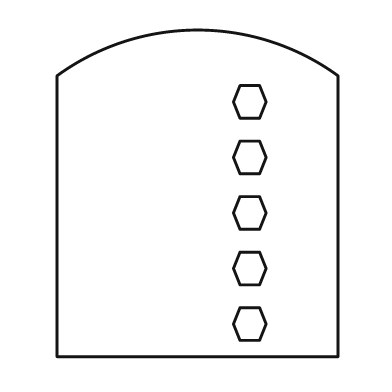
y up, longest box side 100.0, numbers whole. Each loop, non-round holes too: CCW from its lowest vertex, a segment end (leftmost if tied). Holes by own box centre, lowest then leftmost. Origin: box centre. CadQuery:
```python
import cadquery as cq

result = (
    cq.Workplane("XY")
    .moveTo(-43.0, -50.0)
    .lineTo(43.0, -50.0)
    .lineTo(43.0, 36.0)
    .threePointArc((0.0, 50.0), (-43.0, 36.0))
    .close()
    .moveTo(13.0, -45.0)
    .lineTo(19.0, -45.0)
    .lineTo(21.0, -40.0)
    .lineTo(19.0, -35.0)
    .lineTo(13.0, -35.0)
    .lineTo(11.0, -40.0)
    .close()
    .moveTo(13.0, -28.0)
    .lineTo(19.0, -28.0)
    .lineTo(21.0, -23.0)
    .lineTo(19.0, -18.0)
    .lineTo(13.0, -18.0)
    .lineTo(11.0, -23.0)
    .close()
    .moveTo(13.0, -11.0)
    .lineTo(19.0, -11.0)
    .lineTo(21.0, -6.0)
    .lineTo(19.0, -1.0)
    .lineTo(13.0, -1.0)
    .lineTo(11.0, -6.0)
    .close()
    .moveTo(13.0, 6.0)
    .lineTo(19.0, 6.0)
    .lineTo(21.0, 11.0)
    .lineTo(19.0, 16.0)
    .lineTo(13.0, 16.0)
    .lineTo(11.0, 11.0)
    .close()
    .moveTo(13.0, 23.0)
    .lineTo(19.0, 23.0)
    .lineTo(21.0, 28.0)
    .lineTo(19.0, 33.0)
    .lineTo(13.0, 33.0)
    .lineTo(11.0, 28.0)
    .close()
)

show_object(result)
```